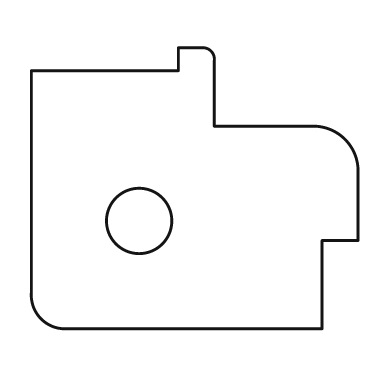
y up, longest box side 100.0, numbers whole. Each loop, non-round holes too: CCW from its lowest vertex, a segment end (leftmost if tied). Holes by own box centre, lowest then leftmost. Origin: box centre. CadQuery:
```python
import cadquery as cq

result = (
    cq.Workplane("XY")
    .moveTo(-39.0, -43.0)
    .lineTo(39.0, -43.0)
    .lineTo(39.0, -16.0)
    .lineTo(50.0, -16.0)
    .lineTo(50.0, 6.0)
    .threePointArc((46.0, 15.0), (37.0, 19.0))
    .lineTo(6.0, 19.0)
    .lineTo(6.0, 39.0)
    .threePointArc((5.0, 42.0), (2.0, 43.0))
    .lineTo(-5.0, 43.0)
    .lineTo(-5.0, 36.0)
    .lineTo(-50.0, 36.0)
    .lineTo(-50.0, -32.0)
    .threePointArc((-47.0, -40.0), (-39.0, -43.0))
    .close()
    .moveTo(-17.0, -10.0)
    .circle(10.0)
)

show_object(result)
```